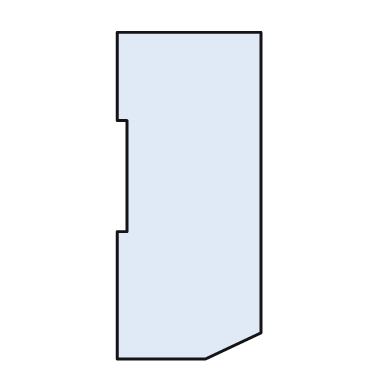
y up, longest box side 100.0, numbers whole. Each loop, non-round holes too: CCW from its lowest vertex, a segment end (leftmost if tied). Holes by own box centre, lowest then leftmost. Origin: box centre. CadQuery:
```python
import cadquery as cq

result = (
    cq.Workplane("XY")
    .moveTo(-22.0, -50.0)
    .lineTo(5.0, -50.0)
    .lineTo(22.0, -42.0)
    .lineTo(22.0, 50.0)
    .lineTo(-22.0, 50.0)
    .lineTo(-22.0, 23.0)
    .lineTo(-19.0, 23.0)
    .lineTo(-19.0, -11.0)
    .lineTo(-22.0, -11.0)
    .close()
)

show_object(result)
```